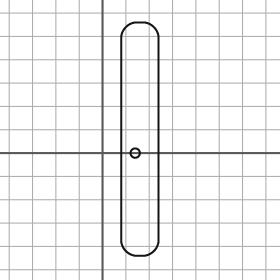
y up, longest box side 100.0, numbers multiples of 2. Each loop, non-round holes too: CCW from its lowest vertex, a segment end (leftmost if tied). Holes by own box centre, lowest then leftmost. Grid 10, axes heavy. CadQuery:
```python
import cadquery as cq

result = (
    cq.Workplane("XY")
    .moveTo(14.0, -44.0)
    .lineTo(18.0, -44.0)
    .threePointArc((22.0, -42.0), (24.0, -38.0))
    .lineTo(24.0, 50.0)
    .threePointArc((22.0, 54.0), (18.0, 56.0))
    .lineTo(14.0, 56.0)
    .threePointArc((10.0, 54.0), (8.0, 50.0))
    .lineTo(8.0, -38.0)
    .threePointArc((10.0, -42.0), (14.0, -44.0))
    .close()
    .moveTo(14.0, 0.0)
    .circle(2.0)
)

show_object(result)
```